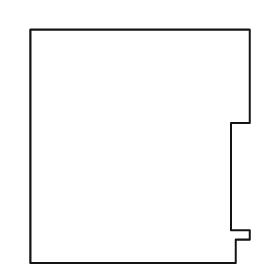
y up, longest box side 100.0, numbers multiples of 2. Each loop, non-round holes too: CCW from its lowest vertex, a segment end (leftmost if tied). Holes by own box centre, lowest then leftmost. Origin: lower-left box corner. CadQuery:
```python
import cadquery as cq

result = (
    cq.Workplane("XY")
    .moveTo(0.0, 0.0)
    .lineTo(88.0, 0.0)
    .lineTo(88.0, 10.0)
    .lineTo(94.0, 10.0)
    .lineTo(94.0, 14.0)
    .lineTo(86.0, 14.0)
    .lineTo(86.0, 60.0)
    .lineTo(94.0, 60.0)
    .lineTo(94.0, 100.0)
    .lineTo(0.0, 100.0)
    .close()
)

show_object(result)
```